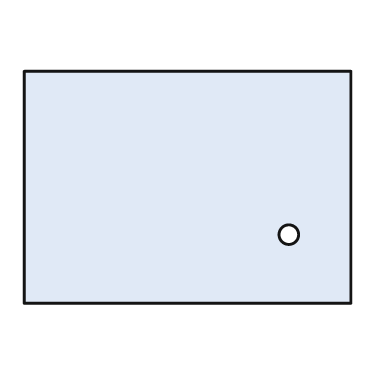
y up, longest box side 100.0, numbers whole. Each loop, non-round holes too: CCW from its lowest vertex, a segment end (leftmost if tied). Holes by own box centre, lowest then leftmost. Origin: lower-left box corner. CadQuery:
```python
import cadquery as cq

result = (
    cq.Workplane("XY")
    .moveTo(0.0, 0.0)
    .lineTo(100.0, 0.0)
    .lineTo(100.0, 71.0)
    .lineTo(0.0, 71.0)
    .close()
    .moveTo(81.0, 21.0)
    .circle(3.0)
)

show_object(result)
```